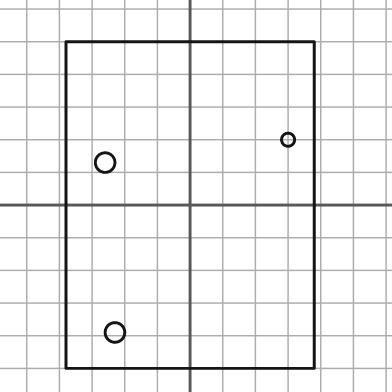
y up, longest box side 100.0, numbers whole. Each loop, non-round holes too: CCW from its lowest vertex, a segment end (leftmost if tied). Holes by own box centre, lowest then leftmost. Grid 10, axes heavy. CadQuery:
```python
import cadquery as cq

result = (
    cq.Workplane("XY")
    .moveTo(-38.0, -50.0)
    .lineTo(38.0, -50.0)
    .lineTo(38.0, 50.0)
    .lineTo(-38.0, 50.0)
    .close()
    .moveTo(-23.0, -39.0)
    .circle(3.0)
    .moveTo(-26.0, 13.0)
    .circle(3.0)
    .moveTo(30.0, 20.0)
    .circle(2.0)
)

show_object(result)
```